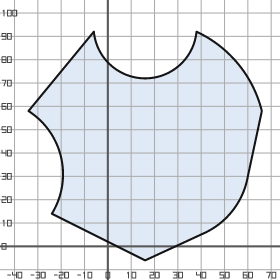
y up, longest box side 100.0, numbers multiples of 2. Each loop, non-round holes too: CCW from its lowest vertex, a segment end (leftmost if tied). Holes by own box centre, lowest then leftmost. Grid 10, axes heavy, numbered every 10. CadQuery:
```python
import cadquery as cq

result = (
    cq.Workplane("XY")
    .moveTo(16.0, -6.0)
    .lineTo(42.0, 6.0)
    .threePointArc((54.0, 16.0), (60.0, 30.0))
    .lineTo(66.0, 58.0)
    .threePointArc((56.0, 78.0), (38.0, 92.0))
    .threePointArc((16.0, 72.0), (-6.0, 92.0))
    .lineTo(-34.0, 58.0)
    .threePointArc((-20.0, 38.0), (-24.0, 14.0))
    .close()
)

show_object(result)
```